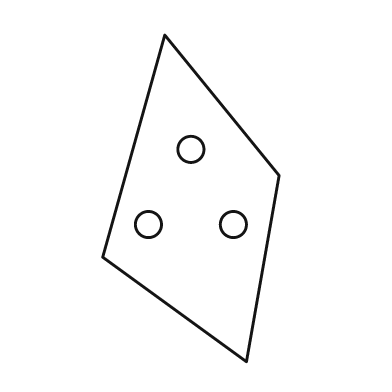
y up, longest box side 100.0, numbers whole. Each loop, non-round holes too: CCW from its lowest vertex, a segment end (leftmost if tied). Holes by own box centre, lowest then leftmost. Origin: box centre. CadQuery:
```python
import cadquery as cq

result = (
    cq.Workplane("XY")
    .moveTo(17.0, -50.0)
    .lineTo(27.0, 7.0)
    .lineTo(-8.0, 50.0)
    .lineTo(-27.0, -18.0)
    .close()
    .moveTo(-13.0, -8.0)
    .circle(4.0)
    .moveTo(13.0, -8.0)
    .circle(4.0)
    .moveTo(0.0, 15.0)
    .circle(4.0)
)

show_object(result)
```